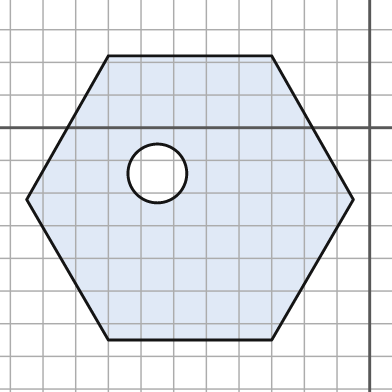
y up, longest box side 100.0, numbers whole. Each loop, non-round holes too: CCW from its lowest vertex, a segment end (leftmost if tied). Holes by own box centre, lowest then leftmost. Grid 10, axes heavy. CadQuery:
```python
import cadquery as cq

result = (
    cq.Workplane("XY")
    .moveTo(-80.0, -65.0)
    .lineTo(-30.0, -65.0)
    .lineTo(-5.0, -22.0)
    .lineTo(-30.0, 22.0)
    .lineTo(-80.0, 22.0)
    .lineTo(-105.0, -22.0)
    .close()
    .moveTo(-65.0, -14.0)
    .circle(9.0)
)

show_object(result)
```